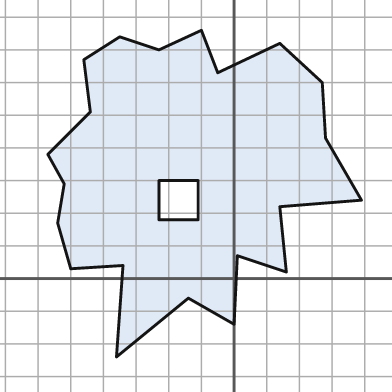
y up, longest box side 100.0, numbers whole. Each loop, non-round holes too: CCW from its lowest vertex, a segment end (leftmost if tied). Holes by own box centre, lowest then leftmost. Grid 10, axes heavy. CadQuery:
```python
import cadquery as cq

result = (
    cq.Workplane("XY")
    .moveTo(-36.0, -24.0)
    .lineTo(-14.0, -6.0)
    .lineTo(0.0, -14.0)
    .lineTo(1.0, 7.0)
    .lineTo(16.0, 2.0)
    .lineTo(14.0, 22.0)
    .lineTo(39.0, 24.0)
    .lineTo(28.0, 43.0)
    .lineTo(27.0, 60.0)
    .lineTo(14.0, 72.0)
    .lineTo(-5.0, 63.0)
    .lineTo(-10.0, 76.0)
    .lineTo(-23.0, 70.0)
    .lineTo(-35.0, 74.0)
    .lineTo(-46.0, 67.0)
    .lineTo(-44.0, 51.0)
    .lineTo(-57.0, 38.0)
    .lineTo(-52.0, 29.0)
    .lineTo(-54.0, 17.0)
    .lineTo(-50.0, 3.0)
    .lineTo(-34.0, 4.0)
    .close()
    .moveTo(-23.0, 18.0)
    .lineTo(-11.0, 18.0)
    .lineTo(-11.0, 30.0)
    .lineTo(-23.0, 30.0)
    .close()
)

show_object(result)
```